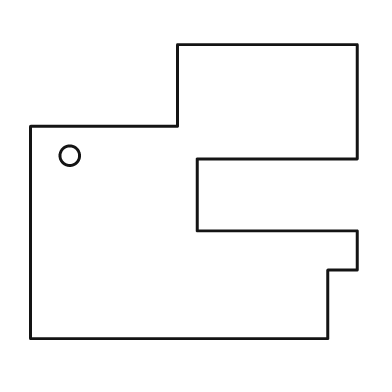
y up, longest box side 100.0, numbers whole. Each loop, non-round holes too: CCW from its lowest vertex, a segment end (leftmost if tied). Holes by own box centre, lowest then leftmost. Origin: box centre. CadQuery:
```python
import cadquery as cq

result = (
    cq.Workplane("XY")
    .moveTo(-50.0, -45.0)
    .lineTo(41.0, -45.0)
    .lineTo(41.0, -24.0)
    .lineTo(50.0, -24.0)
    .lineTo(50.0, -12.0)
    .lineTo(1.0, -12.0)
    .lineTo(1.0, 10.0)
    .lineTo(50.0, 10.0)
    .lineTo(50.0, 45.0)
    .lineTo(-5.0, 45.0)
    .lineTo(-5.0, 20.0)
    .lineTo(-50.0, 20.0)
    .close()
    .moveTo(-38.0, 11.0)
    .circle(3.0)
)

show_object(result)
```